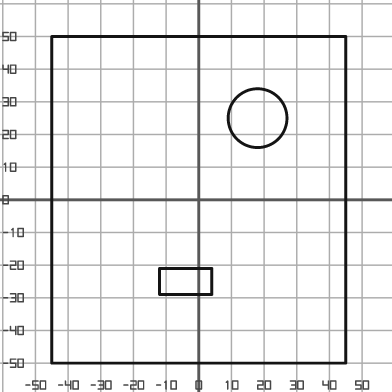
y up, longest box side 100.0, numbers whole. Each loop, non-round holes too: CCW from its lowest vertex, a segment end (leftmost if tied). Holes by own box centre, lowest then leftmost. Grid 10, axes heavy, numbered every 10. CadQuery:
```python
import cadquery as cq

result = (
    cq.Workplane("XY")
    .moveTo(-45.0, -50.0)
    .lineTo(45.0, -50.0)
    .lineTo(45.0, 50.0)
    .lineTo(-45.0, 50.0)
    .close()
    .moveTo(-12.0, -29.0)
    .lineTo(4.0, -29.0)
    .lineTo(4.0, -21.0)
    .lineTo(-12.0, -21.0)
    .close()
    .moveTo(18.0, 25.0)
    .circle(9.0)
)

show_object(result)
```